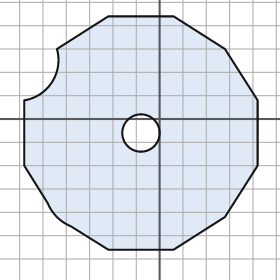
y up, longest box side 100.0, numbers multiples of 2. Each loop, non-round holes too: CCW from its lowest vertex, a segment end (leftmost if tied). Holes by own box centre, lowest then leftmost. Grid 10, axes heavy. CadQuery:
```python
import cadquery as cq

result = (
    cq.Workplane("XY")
    .moveTo(-22.0, -56.0)
    .lineTo(6.0, -56.0)
    .lineTo(28.0, -42.0)
    .lineTo(42.0, -20.0)
    .lineTo(42.0, 8.0)
    .lineTo(28.0, 30.0)
    .lineTo(6.0, 44.0)
    .lineTo(-22.0, 44.0)
    .lineTo(-44.0, 30.0)
    .threePointArc((-46.0, 16.0), (-58.0, 8.0))
    .lineTo(-58.0, -20.0)
    .lineTo(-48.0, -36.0)
    .threePointArc((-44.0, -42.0), (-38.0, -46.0))
    .close()
    .moveTo(-8.0, -6.0)
    .circle(8.0)
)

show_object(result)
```